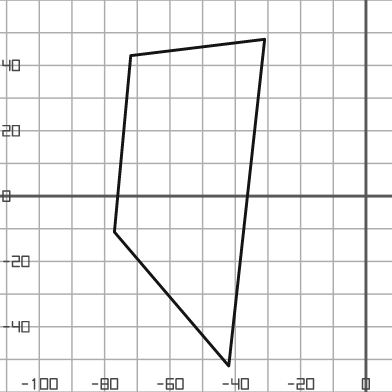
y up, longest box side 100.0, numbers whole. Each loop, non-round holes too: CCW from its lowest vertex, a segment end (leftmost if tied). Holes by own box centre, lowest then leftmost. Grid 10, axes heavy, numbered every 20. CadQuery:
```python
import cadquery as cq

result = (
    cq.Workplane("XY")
    .moveTo(-42.0, -52.0)
    .lineTo(-31.0, 48.0)
    .lineTo(-72.0, 43.0)
    .lineTo(-77.0, -11.0)
    .close()
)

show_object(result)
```